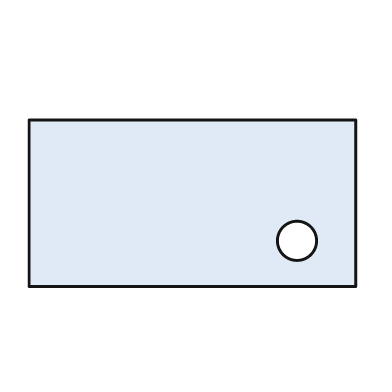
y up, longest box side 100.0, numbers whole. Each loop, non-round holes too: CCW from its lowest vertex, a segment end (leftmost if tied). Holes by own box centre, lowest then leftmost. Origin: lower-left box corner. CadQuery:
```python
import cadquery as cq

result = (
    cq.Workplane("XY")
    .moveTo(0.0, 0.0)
    .lineTo(100.0, 0.0)
    .lineTo(100.0, 51.0)
    .lineTo(0.0, 51.0)
    .close()
    .moveTo(82.0, 14.0)
    .circle(6.0)
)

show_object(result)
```